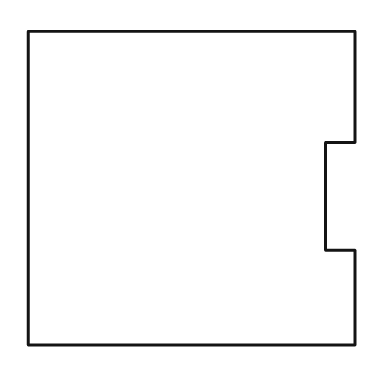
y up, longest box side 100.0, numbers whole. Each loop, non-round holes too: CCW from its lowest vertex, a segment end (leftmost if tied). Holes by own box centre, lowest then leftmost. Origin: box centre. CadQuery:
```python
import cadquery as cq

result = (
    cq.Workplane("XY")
    .moveTo(-50.0, -48.0)
    .lineTo(50.0, -48.0)
    .lineTo(50.0, -19.0)
    .lineTo(41.0, -19.0)
    .lineTo(41.0, 14.0)
    .lineTo(50.0, 14.0)
    .lineTo(50.0, 48.0)
    .lineTo(-50.0, 48.0)
    .close()
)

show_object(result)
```